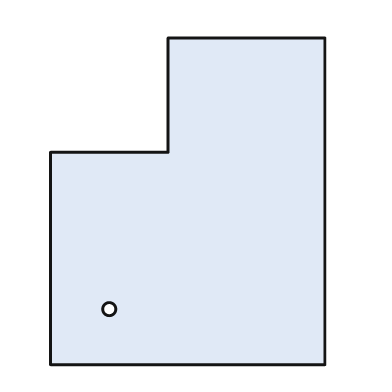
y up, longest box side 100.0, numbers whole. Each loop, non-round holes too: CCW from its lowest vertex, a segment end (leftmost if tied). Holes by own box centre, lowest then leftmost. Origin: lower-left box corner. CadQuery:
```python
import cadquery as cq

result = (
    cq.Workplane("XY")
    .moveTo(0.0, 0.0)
    .lineTo(84.0, 0.0)
    .lineTo(84.0, 100.0)
    .lineTo(36.0, 100.0)
    .lineTo(36.0, 65.0)
    .lineTo(0.0, 65.0)
    .close()
    .moveTo(18.0, 17.0)
    .circle(2.0)
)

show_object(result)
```